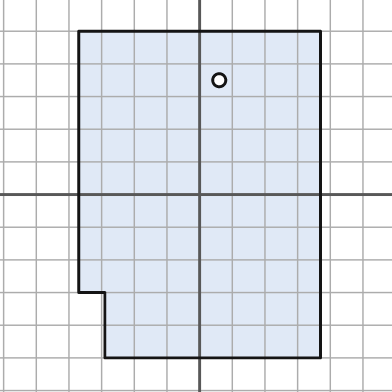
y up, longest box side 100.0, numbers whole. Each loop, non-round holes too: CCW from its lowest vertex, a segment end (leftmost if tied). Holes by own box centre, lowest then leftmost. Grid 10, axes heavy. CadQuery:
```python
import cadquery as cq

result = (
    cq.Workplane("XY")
    .moveTo(-29.0, -50.0)
    .lineTo(37.0, -50.0)
    .lineTo(37.0, 50.0)
    .lineTo(-37.0, 50.0)
    .lineTo(-37.0, -30.0)
    .lineTo(-29.0, -30.0)
    .close()
    .moveTo(6.0, 35.0)
    .circle(2.0)
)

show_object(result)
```